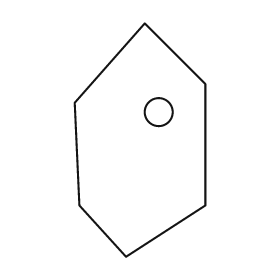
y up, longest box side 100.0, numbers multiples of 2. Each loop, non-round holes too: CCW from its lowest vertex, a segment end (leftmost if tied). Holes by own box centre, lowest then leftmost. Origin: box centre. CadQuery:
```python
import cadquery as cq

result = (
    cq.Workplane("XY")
    .moveTo(-6.0, -50.0)
    .lineTo(28.0, -28.0)
    .lineTo(28.0, 24.0)
    .lineTo(2.0, 50.0)
    .lineTo(-28.0, 16.0)
    .lineTo(-26.0, -28.0)
    .close()
    .moveTo(8.0, 12.0)
    .circle(6.0)
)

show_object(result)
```